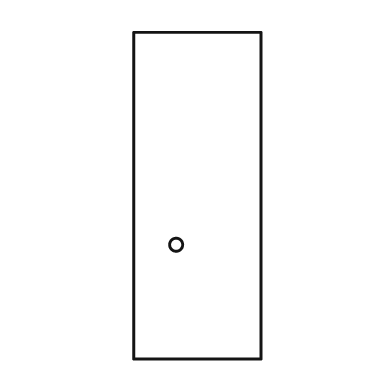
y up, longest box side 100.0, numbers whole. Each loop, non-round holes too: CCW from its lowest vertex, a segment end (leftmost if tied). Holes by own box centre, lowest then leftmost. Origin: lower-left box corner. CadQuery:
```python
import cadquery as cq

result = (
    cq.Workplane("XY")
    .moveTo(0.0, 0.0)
    .lineTo(39.0, 0.0)
    .lineTo(39.0, 100.0)
    .lineTo(0.0, 100.0)
    .close()
    .moveTo(13.0, 35.0)
    .circle(2.0)
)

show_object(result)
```